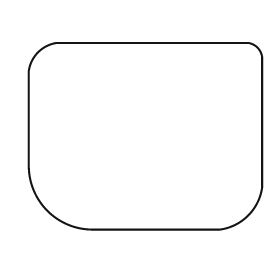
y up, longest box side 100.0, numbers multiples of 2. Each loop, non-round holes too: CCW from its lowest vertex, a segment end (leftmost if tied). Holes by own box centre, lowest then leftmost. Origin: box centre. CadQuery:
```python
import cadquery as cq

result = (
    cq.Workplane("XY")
    .moveTo(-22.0, -40.0)
    .lineTo(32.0, -40.0)
    .threePointArc((44.0, -34.0), (50.0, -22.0))
    .lineTo(50.0, 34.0)
    .threePointArc((48.0, 38.0), (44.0, 40.0))
    .lineTo(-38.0, 40.0)
    .threePointArc((-46.0, 36.0), (-50.0, 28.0))
    .lineTo(-50.0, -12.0)
    .threePointArc((-42.0, -32.0), (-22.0, -40.0))
    .close()
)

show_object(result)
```